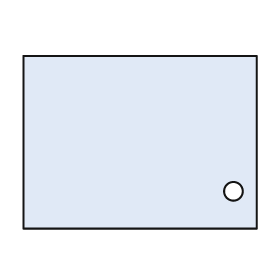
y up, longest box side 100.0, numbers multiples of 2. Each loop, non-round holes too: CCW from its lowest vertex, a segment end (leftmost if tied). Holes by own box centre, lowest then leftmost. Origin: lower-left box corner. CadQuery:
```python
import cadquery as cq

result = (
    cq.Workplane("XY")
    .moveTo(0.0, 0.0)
    .lineTo(100.0, 0.0)
    .lineTo(100.0, 74.0)
    .lineTo(0.0, 74.0)
    .close()
    .moveTo(90.0, 16.0)
    .circle(4.0)
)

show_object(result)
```